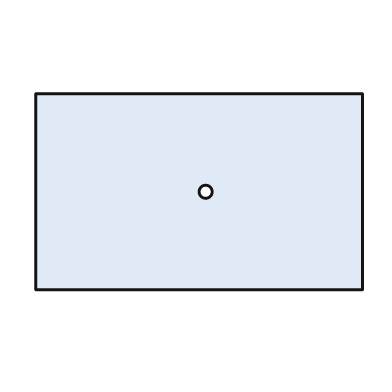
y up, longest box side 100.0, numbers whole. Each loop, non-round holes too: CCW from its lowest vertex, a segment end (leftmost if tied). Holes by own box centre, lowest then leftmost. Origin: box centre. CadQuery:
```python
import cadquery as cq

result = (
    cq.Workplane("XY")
    .moveTo(-50.0, -30.0)
    .lineTo(50.0, -30.0)
    .lineTo(50.0, 30.0)
    .lineTo(-50.0, 30.0)
    .close()
    .moveTo(2.0, 0.0)
    .circle(2.0)
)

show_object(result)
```